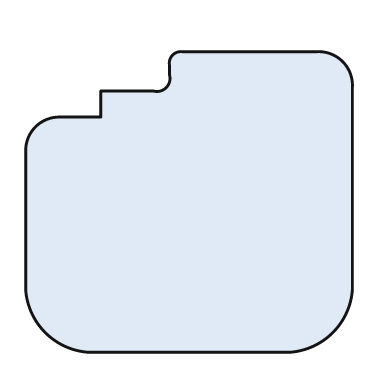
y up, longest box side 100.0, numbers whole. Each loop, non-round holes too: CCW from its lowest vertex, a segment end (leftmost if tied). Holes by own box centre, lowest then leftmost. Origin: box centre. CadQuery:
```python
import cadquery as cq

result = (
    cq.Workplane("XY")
    .moveTo(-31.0, -46.0)
    .lineTo(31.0, -46.0)
    .threePointArc((44.0, -40.0), (50.0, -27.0))
    .lineTo(50.0, 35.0)
    .threePointArc((47.0, 43.0), (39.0, 46.0))
    .lineTo(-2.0, 46.0)
    .threePointArc((-5.0, 45.0), (-6.0, 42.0))
    .lineTo(-6.0, 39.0)
    .threePointArc((-7.0, 35.0), (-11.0, 34.0))
    .lineTo(-27.0, 34.0)
    .lineTo(-27.0, 26.0)
    .lineTo(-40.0, 26.0)
    .threePointArc((-47.0, 23.0), (-50.0, 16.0))
    .lineTo(-50.0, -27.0)
    .threePointArc((-44.0, -40.0), (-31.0, -46.0))
    .close()
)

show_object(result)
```